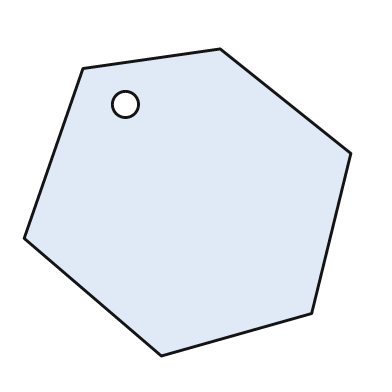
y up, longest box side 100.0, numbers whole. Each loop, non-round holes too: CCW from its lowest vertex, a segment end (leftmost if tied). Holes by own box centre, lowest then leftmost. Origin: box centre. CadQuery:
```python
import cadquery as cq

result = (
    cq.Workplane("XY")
    .moveTo(-8.0, -47.0)
    .lineTo(38.0, -34.0)
    .lineTo(50.0, 15.0)
    .lineTo(10.0, 47.0)
    .lineTo(-32.0, 41.0)
    .lineTo(-50.0, -11.0)
    .close()
    .moveTo(-19.0, 30.0)
    .circle(4.0)
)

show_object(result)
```